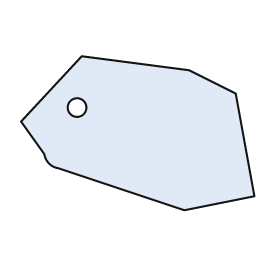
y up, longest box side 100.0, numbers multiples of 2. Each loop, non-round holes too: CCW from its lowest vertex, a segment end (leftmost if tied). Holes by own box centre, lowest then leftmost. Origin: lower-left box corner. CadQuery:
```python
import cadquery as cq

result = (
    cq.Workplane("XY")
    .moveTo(70.0, 0.0)
    .lineTo(100.0, 6.0)
    .lineTo(92.0, 50.0)
    .lineTo(72.0, 60.0)
    .lineTo(26.0, 66.0)
    .lineTo(0.0, 38.0)
    .lineTo(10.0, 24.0)
    .threePointArc((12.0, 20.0), (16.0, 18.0))
    .close()
    .moveTo(24.0, 44.0)
    .circle(4.0)
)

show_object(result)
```